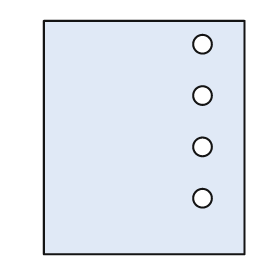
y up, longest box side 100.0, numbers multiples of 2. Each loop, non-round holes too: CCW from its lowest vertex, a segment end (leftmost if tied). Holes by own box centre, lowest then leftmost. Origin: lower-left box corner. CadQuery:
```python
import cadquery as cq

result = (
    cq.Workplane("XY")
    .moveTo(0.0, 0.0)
    .lineTo(86.0, 0.0)
    .lineTo(86.0, 100.0)
    .lineTo(0.0, 100.0)
    .close()
    .moveTo(68.0, 24.0)
    .circle(4.0)
    .moveTo(68.0, 46.0)
    .circle(4.0)
    .moveTo(68.0, 68.0)
    .circle(4.0)
    .moveTo(68.0, 90.0)
    .circle(4.0)
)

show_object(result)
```